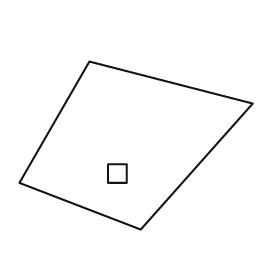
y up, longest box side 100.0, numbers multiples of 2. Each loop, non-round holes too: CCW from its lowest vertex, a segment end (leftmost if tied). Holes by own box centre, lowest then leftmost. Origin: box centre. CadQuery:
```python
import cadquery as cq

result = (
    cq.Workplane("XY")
    .moveTo(2.0, -36.0)
    .lineTo(50.0, 18.0)
    .lineTo(-20.0, 36.0)
    .lineTo(-50.0, -16.0)
    .close()
    .moveTo(-12.0, -16.0)
    .lineTo(-4.0, -16.0)
    .lineTo(-4.0, -8.0)
    .lineTo(-12.0, -8.0)
    .close()
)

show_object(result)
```